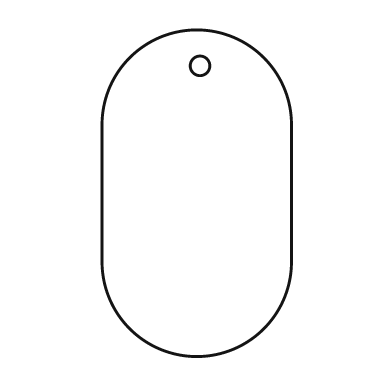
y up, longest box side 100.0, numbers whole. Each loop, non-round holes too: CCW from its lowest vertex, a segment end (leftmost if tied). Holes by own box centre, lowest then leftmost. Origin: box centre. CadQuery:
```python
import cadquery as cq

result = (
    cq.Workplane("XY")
    .moveTo(-29.0, -21.0)
    .threePointArc((0.0, -50.0), (29.0, -21.0))
    .lineTo(29.0, 21.0)
    .threePointArc((0.0, 50.0), (-29.0, 21.0))
    .close()
    .moveTo(1.0, 39.0)
    .circle(3.0)
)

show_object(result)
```